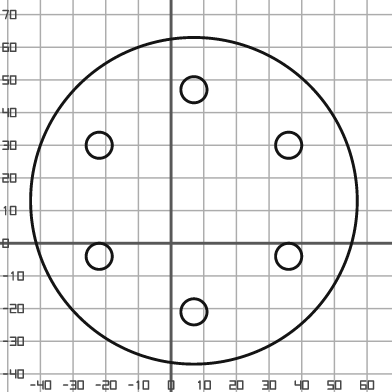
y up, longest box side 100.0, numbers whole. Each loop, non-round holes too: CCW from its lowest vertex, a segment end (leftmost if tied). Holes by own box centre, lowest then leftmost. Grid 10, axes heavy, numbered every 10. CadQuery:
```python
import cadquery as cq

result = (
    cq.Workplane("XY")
    .moveTo(7.0, 13.0)
    .circle(50.0)
    .moveTo(7.0, -21.0)
    .circle(4.0)
    .moveTo(-22.0, -4.0)
    .circle(4.0)
    .moveTo(36.0, -4.0)
    .circle(4.0)
    .moveTo(-22.0, 30.0)
    .circle(4.0)
    .moveTo(36.0, 30.0)
    .circle(4.0)
    .moveTo(7.0, 47.0)
    .circle(4.0)
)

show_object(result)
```